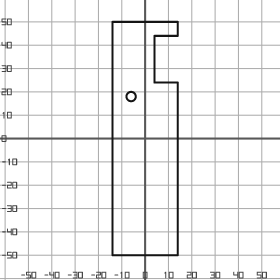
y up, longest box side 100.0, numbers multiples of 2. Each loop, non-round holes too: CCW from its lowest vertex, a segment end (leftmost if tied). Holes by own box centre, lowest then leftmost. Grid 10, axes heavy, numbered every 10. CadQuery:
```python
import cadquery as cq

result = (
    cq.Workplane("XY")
    .moveTo(-14.0, -50.0)
    .lineTo(14.0, -50.0)
    .lineTo(14.0, 24.0)
    .lineTo(4.0, 24.0)
    .lineTo(4.0, 44.0)
    .lineTo(14.0, 44.0)
    .lineTo(14.0, 50.0)
    .lineTo(-14.0, 50.0)
    .close()
    .moveTo(-6.0, 18.0)
    .circle(2.0)
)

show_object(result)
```